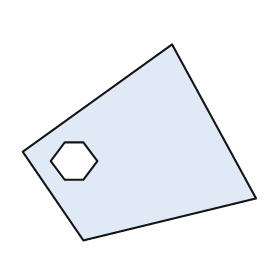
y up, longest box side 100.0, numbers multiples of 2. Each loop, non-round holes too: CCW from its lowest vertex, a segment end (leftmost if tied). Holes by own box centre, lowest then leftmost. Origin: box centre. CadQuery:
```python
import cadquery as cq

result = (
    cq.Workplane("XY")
    .moveTo(-24.0, -42.0)
    .lineTo(50.0, -24.0)
    .lineTo(14.0, 42.0)
    .lineTo(-50.0, -4.0)
    .close()
    .moveTo(-32.0, -16.0)
    .lineTo(-24.0, -16.0)
    .lineTo(-18.0, -8.0)
    .lineTo(-24.0, 0.0)
    .lineTo(-32.0, 0.0)
    .lineTo(-38.0, -8.0)
    .close()
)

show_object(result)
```